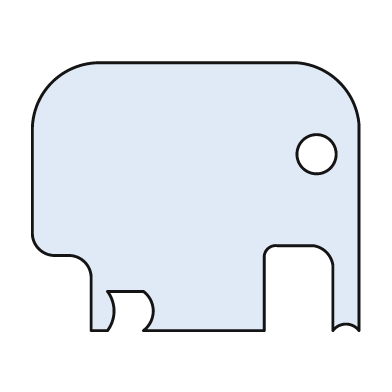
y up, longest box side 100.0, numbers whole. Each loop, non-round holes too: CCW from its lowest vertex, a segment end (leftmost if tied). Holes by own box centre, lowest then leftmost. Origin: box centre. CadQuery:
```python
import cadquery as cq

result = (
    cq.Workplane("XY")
    .moveTo(-32.0, -41.0)
    .lineTo(-27.0, -41.0)
    .threePointArc((-25.0, -35.0), (-27.0, -29.0))
    .lineTo(-16.0, -29.0)
    .threePointArc((-13.0, -35.0), (-16.0, -41.0))
    .lineTo(21.0, -41.0)
    .lineTo(21.0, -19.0)
    .threePointArc((22.0, -16.0), (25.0, -15.0))
    .lineTo(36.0, -15.0)
    .threePointArc((40.0, -17.0), (42.0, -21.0))
    .lineTo(42.0, -41.0)
    .threePointArc((46.0, -39.0), (50.0, -41.0))
    .lineTo(50.0, 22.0)
    .threePointArc((44.0, 35.0), (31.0, 41.0))
    .lineTo(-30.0, 41.0)
    .threePointArc((-44.0, 35.0), (-50.0, 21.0))
    .lineTo(-50.0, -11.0)
    .threePointArc((-48.0, -16.0), (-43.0, -18.0))
    .lineTo(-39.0, -18.0)
    .threePointArc((-34.0, -20.0), (-32.0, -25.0))
    .close()
    .moveTo(37.0, 13.0)
    .circle(6.0)
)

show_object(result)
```